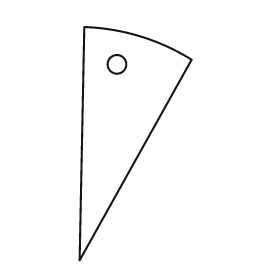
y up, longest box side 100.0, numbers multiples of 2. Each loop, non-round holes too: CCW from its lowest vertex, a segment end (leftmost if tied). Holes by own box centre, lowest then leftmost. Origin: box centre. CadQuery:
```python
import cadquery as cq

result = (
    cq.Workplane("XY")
    .moveTo(-24.0, -50.0)
    .lineTo(24.0, 36.0)
    .threePointArc((2.0, 46.0), (-22.0, 50.0))
    .close()
    .moveTo(-8.0, 34.0)
    .circle(4.0)
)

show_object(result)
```